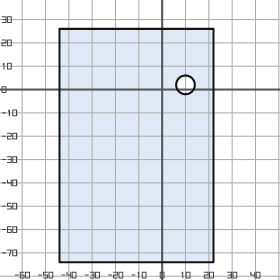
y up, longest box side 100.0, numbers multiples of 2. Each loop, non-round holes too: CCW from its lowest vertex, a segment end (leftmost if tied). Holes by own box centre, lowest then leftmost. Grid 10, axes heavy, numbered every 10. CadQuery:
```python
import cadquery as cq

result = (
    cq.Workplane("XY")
    .moveTo(-44.0, -74.0)
    .lineTo(22.0, -74.0)
    .lineTo(22.0, 26.0)
    .lineTo(-44.0, 26.0)
    .close()
    .moveTo(10.0, 2.0)
    .circle(4.0)
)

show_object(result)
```